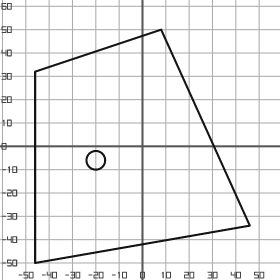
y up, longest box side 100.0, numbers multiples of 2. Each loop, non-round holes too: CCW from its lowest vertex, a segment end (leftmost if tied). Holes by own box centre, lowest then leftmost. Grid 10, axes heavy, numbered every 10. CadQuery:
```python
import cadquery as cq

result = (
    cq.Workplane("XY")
    .moveTo(-46.0, -50.0)
    .lineTo(46.0, -34.0)
    .lineTo(8.0, 50.0)
    .lineTo(-46.0, 32.0)
    .close()
    .moveTo(-20.0, -6.0)
    .circle(4.0)
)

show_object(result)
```